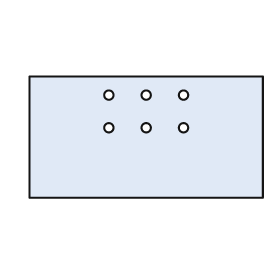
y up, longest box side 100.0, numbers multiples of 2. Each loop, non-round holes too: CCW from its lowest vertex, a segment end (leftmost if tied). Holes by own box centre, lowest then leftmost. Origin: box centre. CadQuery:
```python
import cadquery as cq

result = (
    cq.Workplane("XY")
    .moveTo(-50.0, -26.0)
    .lineTo(50.0, -26.0)
    .lineTo(50.0, 26.0)
    .lineTo(-50.0, 26.0)
    .close()
    .moveTo(-16.0, 4.0)
    .circle(2.0)
    .moveTo(0.0, 4.0)
    .circle(2.0)
    .moveTo(16.0, 4.0)
    .circle(2.0)
    .moveTo(-16.0, 18.0)
    .circle(2.0)
    .moveTo(0.0, 18.0)
    .circle(2.0)
    .moveTo(16.0, 18.0)
    .circle(2.0)
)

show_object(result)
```